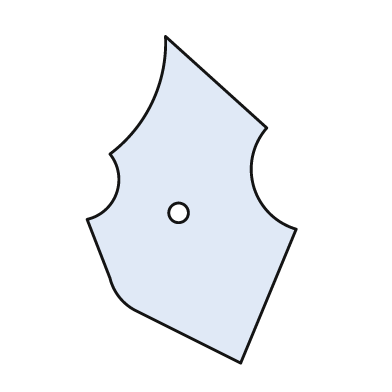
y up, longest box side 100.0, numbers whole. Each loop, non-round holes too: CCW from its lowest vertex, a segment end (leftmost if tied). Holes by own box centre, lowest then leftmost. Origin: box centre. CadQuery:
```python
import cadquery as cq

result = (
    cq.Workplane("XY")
    .moveTo(15.0, -50.0)
    .lineTo(32.0, -9.0)
    .threePointArc((19.0, 4.0), (23.0, 22.0))
    .lineTo(-8.0, 50.0)
    .threePointArc((-12.0, 30.0), (-25.0, 14.0))
    .threePointArc((-23.0, 2.0), (-32.0, -6.0))
    .lineTo(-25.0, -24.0)
    .threePointArc((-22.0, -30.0), (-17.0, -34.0))
    .close()
    .moveTo(-4.0, -4.0)
    .circle(3.0)
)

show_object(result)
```